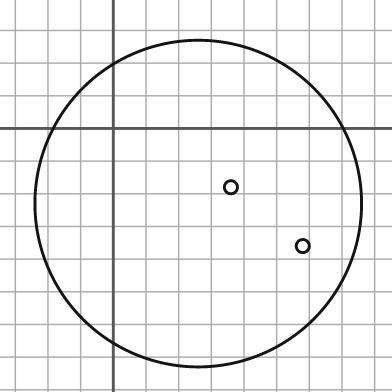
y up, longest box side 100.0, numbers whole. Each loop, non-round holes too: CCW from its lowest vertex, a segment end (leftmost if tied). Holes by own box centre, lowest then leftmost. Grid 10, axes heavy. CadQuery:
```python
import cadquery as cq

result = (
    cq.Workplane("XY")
    .moveTo(26.0, -23.0)
    .circle(50.0)
    .moveTo(58.0, -36.0)
    .circle(2.0)
    .moveTo(36.0, -18.0)
    .circle(2.0)
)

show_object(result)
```